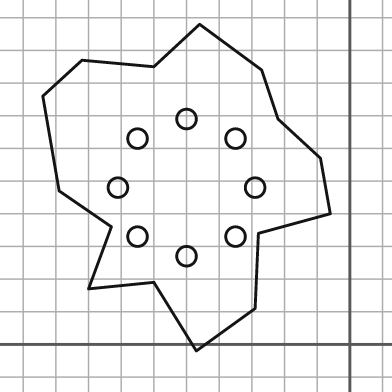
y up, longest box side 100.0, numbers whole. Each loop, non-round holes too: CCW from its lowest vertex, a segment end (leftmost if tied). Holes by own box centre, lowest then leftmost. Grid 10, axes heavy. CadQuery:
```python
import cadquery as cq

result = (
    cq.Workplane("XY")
    .moveTo(-47.0, -2.0)
    .lineTo(-29.0, 11.0)
    .lineTo(-28.0, 34.0)
    .lineTo(-6.0, 40.0)
    .lineTo(-9.0, 57.0)
    .lineTo(-22.0, 69.0)
    .lineTo(-27.0, 84.0)
    .lineTo(-46.0, 98.0)
    .lineTo(-60.0, 85.0)
    .lineTo(-82.0, 87.0)
    .lineTo(-94.0, 76.0)
    .lineTo(-89.0, 47.0)
    .lineTo(-73.0, 36.0)
    .lineTo(-80.0, 17.0)
    .lineTo(-60.0, 19.0)
    .close()
    .moveTo(-50.0, 27.0)
    .circle(3.0)
    .moveTo(-65.0, 33.0)
    .circle(3.0)
    .moveTo(-35.0, 33.0)
    .circle(3.0)
    .moveTo(-71.0, 48.0)
    .circle(3.0)
    .moveTo(-29.0, 48.0)
    .circle(3.0)
    .moveTo(-65.0, 63.0)
    .circle(3.0)
    .moveTo(-35.0, 63.0)
    .circle(3.0)
    .moveTo(-50.0, 69.0)
    .circle(3.0)
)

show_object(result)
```